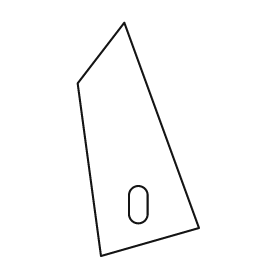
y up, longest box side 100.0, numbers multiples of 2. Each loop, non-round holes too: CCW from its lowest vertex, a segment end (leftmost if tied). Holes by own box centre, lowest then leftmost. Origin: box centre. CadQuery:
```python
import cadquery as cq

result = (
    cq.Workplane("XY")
    .moveTo(-16.0, -50.0)
    .lineTo(26.0, -38.0)
    .lineTo(-6.0, 50.0)
    .lineTo(-26.0, 24.0)
    .close()
    .moveTo(-4.0, -32.0)
    .threePointArc((0.0, -36.0), (4.0, -32.0))
    .lineTo(4.0, -24.0)
    .threePointArc((0.0, -20.0), (-4.0, -24.0))
    .close()
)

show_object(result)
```